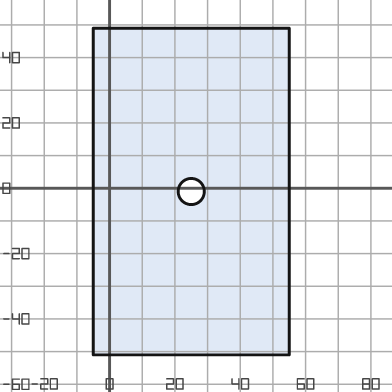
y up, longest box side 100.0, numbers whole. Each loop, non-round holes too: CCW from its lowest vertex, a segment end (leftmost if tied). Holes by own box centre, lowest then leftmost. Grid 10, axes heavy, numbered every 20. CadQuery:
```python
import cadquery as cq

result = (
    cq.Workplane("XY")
    .moveTo(-5.0, -51.0)
    .lineTo(55.0, -51.0)
    .lineTo(55.0, 49.0)
    .lineTo(-5.0, 49.0)
    .close()
    .moveTo(25.0, -1.0)
    .circle(4.0)
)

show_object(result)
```